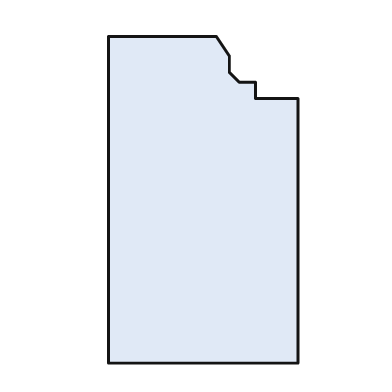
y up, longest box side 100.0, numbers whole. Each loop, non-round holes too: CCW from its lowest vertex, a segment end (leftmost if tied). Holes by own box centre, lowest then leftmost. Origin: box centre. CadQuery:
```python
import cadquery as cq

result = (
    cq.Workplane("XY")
    .moveTo(-29.0, -50.0)
    .lineTo(29.0, -50.0)
    .lineTo(29.0, 31.0)
    .lineTo(16.0, 31.0)
    .lineTo(16.0, 36.0)
    .lineTo(11.0, 36.0)
    .lineTo(8.0, 39.0)
    .lineTo(8.0, 44.0)
    .lineTo(4.0, 50.0)
    .lineTo(-29.0, 50.0)
    .close()
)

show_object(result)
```